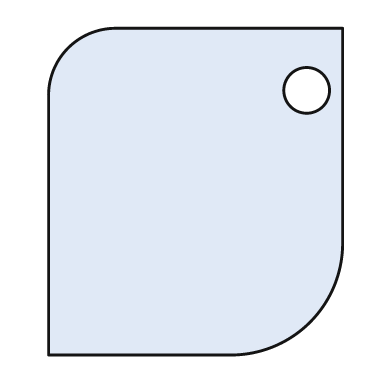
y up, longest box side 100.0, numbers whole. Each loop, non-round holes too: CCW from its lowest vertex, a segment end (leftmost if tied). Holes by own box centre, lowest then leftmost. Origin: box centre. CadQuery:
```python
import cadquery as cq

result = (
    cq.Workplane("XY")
    .moveTo(-45.0, -50.0)
    .lineTo(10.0, -50.0)
    .threePointArc((35.0, -40.0), (45.0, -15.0))
    .lineTo(45.0, 50.0)
    .lineTo(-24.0, 50.0)
    .threePointArc((-39.0, 44.0), (-45.0, 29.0))
    .close()
    .moveTo(34.0, 31.0)
    .circle(7.0)
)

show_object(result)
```